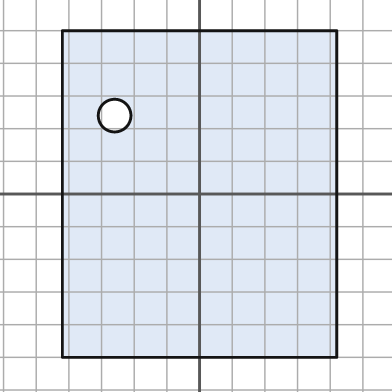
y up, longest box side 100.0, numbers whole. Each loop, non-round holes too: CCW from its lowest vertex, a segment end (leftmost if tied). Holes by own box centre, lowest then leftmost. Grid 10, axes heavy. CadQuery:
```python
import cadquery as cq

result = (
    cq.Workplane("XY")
    .moveTo(-42.0, -50.0)
    .lineTo(42.0, -50.0)
    .lineTo(42.0, 50.0)
    .lineTo(-42.0, 50.0)
    .close()
    .moveTo(-26.0, 24.0)
    .circle(5.0)
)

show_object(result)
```